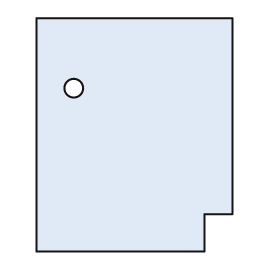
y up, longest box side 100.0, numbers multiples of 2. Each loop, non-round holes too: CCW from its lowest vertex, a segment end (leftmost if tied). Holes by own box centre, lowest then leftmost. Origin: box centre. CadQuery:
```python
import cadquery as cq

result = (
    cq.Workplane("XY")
    .moveTo(-42.0, -50.0)
    .lineTo(30.0, -50.0)
    .lineTo(30.0, -34.0)
    .lineTo(42.0, -34.0)
    .lineTo(42.0, 50.0)
    .lineTo(-42.0, 50.0)
    .close()
    .moveTo(-26.0, 20.0)
    .circle(4.0)
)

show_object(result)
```